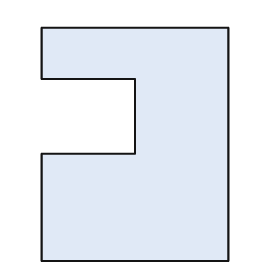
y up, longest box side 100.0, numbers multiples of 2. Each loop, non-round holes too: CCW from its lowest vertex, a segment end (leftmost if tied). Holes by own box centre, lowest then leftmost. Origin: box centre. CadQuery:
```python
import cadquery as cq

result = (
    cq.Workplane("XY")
    .moveTo(-40.0, -50.0)
    .lineTo(40.0, -50.0)
    .lineTo(40.0, 50.0)
    .lineTo(-40.0, 50.0)
    .lineTo(-40.0, 28.0)
    .lineTo(0.0, 28.0)
    .lineTo(0.0, -4.0)
    .lineTo(-40.0, -4.0)
    .close()
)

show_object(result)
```